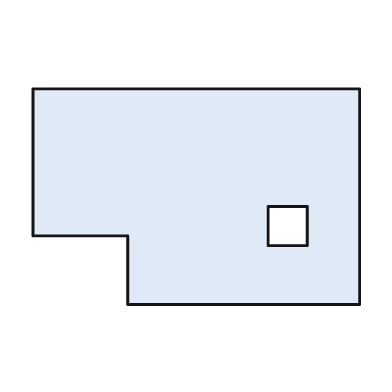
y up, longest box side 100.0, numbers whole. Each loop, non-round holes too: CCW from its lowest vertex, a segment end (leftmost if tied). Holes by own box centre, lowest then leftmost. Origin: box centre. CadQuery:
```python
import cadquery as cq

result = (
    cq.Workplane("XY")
    .moveTo(-21.0, -33.0)
    .lineTo(50.0, -33.0)
    .lineTo(50.0, 33.0)
    .lineTo(-50.0, 33.0)
    .lineTo(-50.0, -12.0)
    .lineTo(-21.0, -12.0)
    .close()
    .moveTo(22.0, -15.0)
    .lineTo(34.0, -15.0)
    .lineTo(34.0, -3.0)
    .lineTo(22.0, -3.0)
    .close()
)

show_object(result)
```